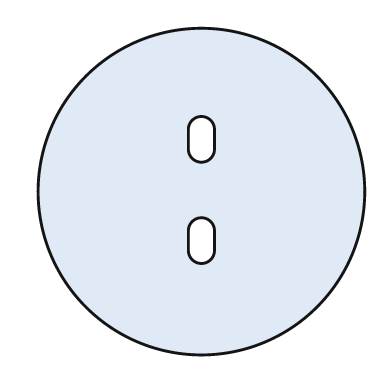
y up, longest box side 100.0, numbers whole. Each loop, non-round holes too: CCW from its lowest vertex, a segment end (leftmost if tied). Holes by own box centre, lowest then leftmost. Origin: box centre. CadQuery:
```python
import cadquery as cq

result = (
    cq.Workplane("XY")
    .moveTo(0.0, 0.0)
    .circle(50.0)
    .moveTo(-4.0, -18.0)
    .threePointArc((0.0, -22.0), (4.0, -18.0))
    .lineTo(4.0, -12.0)
    .threePointArc((0.0, -8.0), (-4.0, -12.0))
    .close()
    .moveTo(-4.0, 13.0)
    .threePointArc((0.0, 9.0), (4.0, 13.0))
    .lineTo(4.0, 19.0)
    .threePointArc((0.0, 23.0), (-4.0, 19.0))
    .close()
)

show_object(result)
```